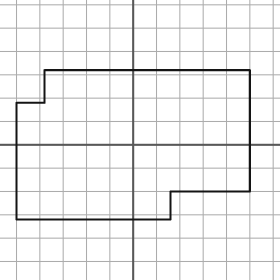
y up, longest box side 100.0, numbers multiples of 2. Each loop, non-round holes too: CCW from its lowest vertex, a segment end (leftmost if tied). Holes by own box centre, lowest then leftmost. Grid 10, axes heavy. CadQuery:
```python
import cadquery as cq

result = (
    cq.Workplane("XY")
    .moveTo(-50.0, -32.0)
    .lineTo(16.0, -32.0)
    .lineTo(16.0, -20.0)
    .lineTo(50.0, -20.0)
    .lineTo(50.0, 32.0)
    .lineTo(-38.0, 32.0)
    .lineTo(-38.0, 18.0)
    .lineTo(-50.0, 18.0)
    .close()
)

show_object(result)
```